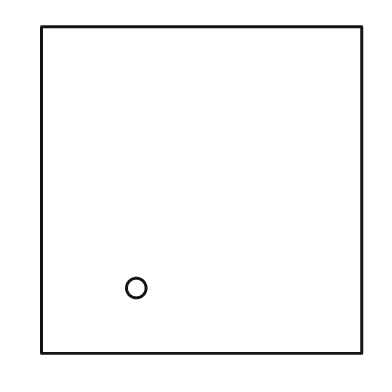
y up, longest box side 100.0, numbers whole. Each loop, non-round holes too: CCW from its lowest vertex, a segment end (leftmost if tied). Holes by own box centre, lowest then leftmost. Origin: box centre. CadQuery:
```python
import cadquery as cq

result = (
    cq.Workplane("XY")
    .moveTo(-49.0, -50.0)
    .lineTo(49.0, -50.0)
    .lineTo(49.0, 50.0)
    .lineTo(-49.0, 50.0)
    .close()
    .moveTo(-20.0, -30.0)
    .circle(3.0)
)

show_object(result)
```